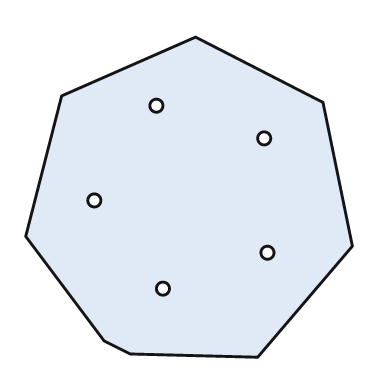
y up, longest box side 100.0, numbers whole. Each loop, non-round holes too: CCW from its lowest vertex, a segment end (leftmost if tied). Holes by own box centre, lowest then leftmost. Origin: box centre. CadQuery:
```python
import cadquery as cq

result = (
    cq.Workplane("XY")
    .moveTo(21.0, -49.0)
    .lineTo(50.0, -15.0)
    .lineTo(41.0, 29.0)
    .lineTo(2.0, 49.0)
    .lineTo(-39.0, 31.0)
    .lineTo(-50.0, -12.0)
    .lineTo(-26.0, -44.0)
    .lineTo(-18.0, -48.0)
    .close()
    .moveTo(-8.0, -28.0)
    .circle(2.0)
    .moveTo(24.0, -17.0)
    .circle(2.0)
    .moveTo(-29.0, -1.0)
    .circle(2.0)
    .moveTo(23.0, 18.0)
    .circle(2.0)
    .moveTo(-10.0, 28.0)
    .circle(2.0)
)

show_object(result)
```